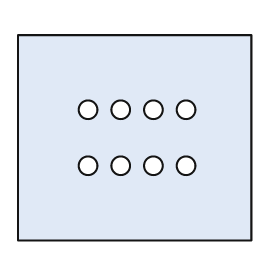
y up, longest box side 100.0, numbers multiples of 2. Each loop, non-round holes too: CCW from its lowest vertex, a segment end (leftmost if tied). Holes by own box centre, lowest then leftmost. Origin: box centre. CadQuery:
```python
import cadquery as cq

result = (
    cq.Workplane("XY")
    .moveTo(-50.0, -44.0)
    .lineTo(50.0, -44.0)
    .lineTo(50.0, 44.0)
    .lineTo(-50.0, 44.0)
    .close()
    .moveTo(-20.0, -12.0)
    .circle(4.0)
    .moveTo(-6.0, -12.0)
    .circle(4.0)
    .moveTo(8.0, -12.0)
    .circle(4.0)
    .moveTo(22.0, -12.0)
    .circle(4.0)
    .moveTo(-20.0, 12.0)
    .circle(4.0)
    .moveTo(-6.0, 12.0)
    .circle(4.0)
    .moveTo(8.0, 12.0)
    .circle(4.0)
    .moveTo(22.0, 12.0)
    .circle(4.0)
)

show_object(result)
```